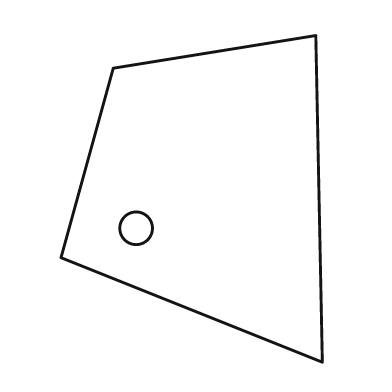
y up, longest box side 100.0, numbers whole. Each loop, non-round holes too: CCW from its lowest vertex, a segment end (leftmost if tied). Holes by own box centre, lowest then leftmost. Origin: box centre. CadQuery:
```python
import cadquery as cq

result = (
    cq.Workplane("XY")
    .moveTo(40.0, -50.0)
    .lineTo(38.0, 50.0)
    .lineTo(-24.0, 40.0)
    .lineTo(-40.0, -18.0)
    .close()
    .moveTo(-17.0, -9.0)
    .circle(5.0)
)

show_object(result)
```